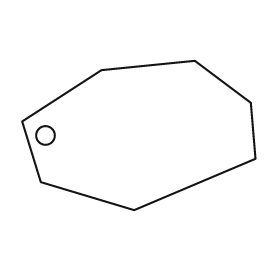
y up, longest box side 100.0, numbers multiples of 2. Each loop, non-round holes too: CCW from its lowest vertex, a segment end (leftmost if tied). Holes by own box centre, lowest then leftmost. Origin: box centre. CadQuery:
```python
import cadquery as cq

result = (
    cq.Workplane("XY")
    .moveTo(-2.0, -32.0)
    .lineTo(50.0, -10.0)
    .lineTo(48.0, 14.0)
    .lineTo(24.0, 32.0)
    .lineTo(-16.0, 28.0)
    .lineTo(-50.0, 6.0)
    .lineTo(-42.0, -20.0)
    .close()
    .moveTo(-40.0, 0.0)
    .circle(4.0)
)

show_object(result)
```